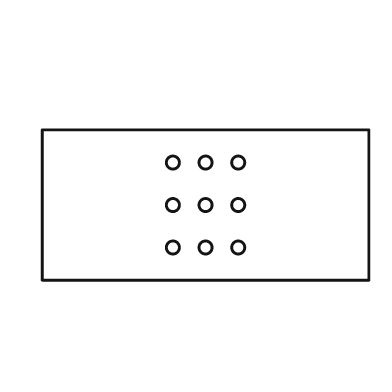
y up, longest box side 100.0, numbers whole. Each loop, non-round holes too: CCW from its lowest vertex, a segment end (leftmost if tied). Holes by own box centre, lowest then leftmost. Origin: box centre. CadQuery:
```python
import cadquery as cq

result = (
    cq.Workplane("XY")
    .moveTo(-50.0, -23.0)
    .lineTo(50.0, -23.0)
    .lineTo(50.0, 23.0)
    .lineTo(-50.0, 23.0)
    .close()
    .moveTo(-10.0, -13.0)
    .circle(2.0)
    .moveTo(0.0, -13.0)
    .circle(2.0)
    .moveTo(10.0, -13.0)
    .circle(2.0)
    .moveTo(-10.0, 0.0)
    .circle(2.0)
    .moveTo(0.0, 0.0)
    .circle(2.0)
    .moveTo(10.0, 0.0)
    .circle(2.0)
    .moveTo(-10.0, 13.0)
    .circle(2.0)
    .moveTo(0.0, 13.0)
    .circle(2.0)
    .moveTo(10.0, 13.0)
    .circle(2.0)
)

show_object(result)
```